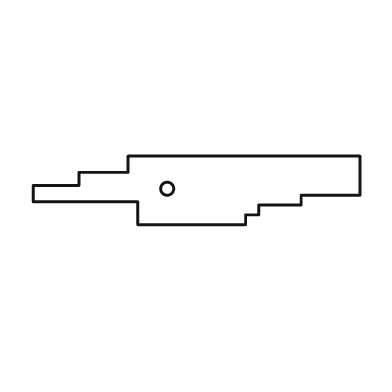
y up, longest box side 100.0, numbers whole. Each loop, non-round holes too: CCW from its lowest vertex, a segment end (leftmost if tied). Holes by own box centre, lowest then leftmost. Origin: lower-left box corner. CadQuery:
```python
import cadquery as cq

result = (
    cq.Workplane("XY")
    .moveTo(32.0, 0.0)
    .lineTo(65.0, 0.0)
    .lineTo(65.0, 3.0)
    .lineTo(69.0, 3.0)
    .lineTo(69.0, 6.0)
    .lineTo(82.0, 6.0)
    .lineTo(82.0, 9.0)
    .lineTo(100.0, 9.0)
    .lineTo(100.0, 21.0)
    .lineTo(29.0, 21.0)
    .lineTo(29.0, 16.0)
    .lineTo(14.0, 16.0)
    .lineTo(14.0, 12.0)
    .lineTo(0.0, 12.0)
    .lineTo(0.0, 7.0)
    .lineTo(32.0, 7.0)
    .close()
    .moveTo(41.0, 11.0)
    .circle(2.0)
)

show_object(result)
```